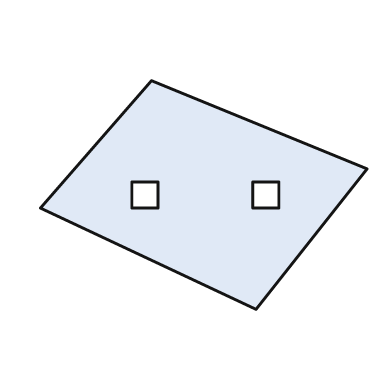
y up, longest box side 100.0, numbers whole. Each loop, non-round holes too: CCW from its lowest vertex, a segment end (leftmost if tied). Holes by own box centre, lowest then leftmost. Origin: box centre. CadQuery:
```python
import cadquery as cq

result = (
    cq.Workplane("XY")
    .moveTo(16.0, -35.0)
    .lineTo(50.0, 8.0)
    .lineTo(-16.0, 35.0)
    .lineTo(-50.0, -4.0)
    .close()
    .moveTo(-22.0, -4.0)
    .lineTo(-14.0, -4.0)
    .lineTo(-14.0, 4.0)
    .lineTo(-22.0, 4.0)
    .close()
    .moveTo(15.0, -4.0)
    .lineTo(23.0, -4.0)
    .lineTo(23.0, 4.0)
    .lineTo(15.0, 4.0)
    .close()
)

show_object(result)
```